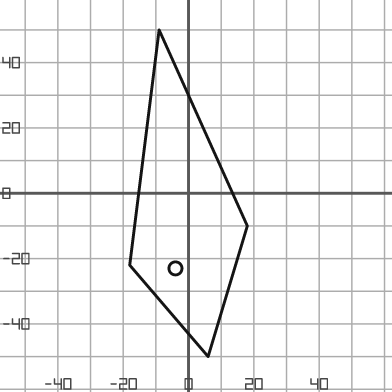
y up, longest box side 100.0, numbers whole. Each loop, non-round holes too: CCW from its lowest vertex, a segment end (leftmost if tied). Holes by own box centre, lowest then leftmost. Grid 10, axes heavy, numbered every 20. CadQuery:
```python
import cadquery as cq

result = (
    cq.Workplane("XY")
    .moveTo(6.0, -50.0)
    .lineTo(18.0, -10.0)
    .lineTo(-9.0, 50.0)
    .lineTo(-18.0, -22.0)
    .close()
    .moveTo(-4.0, -23.0)
    .circle(2.0)
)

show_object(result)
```